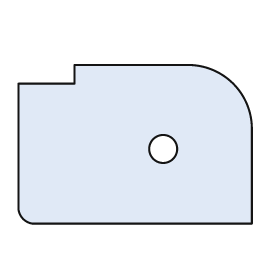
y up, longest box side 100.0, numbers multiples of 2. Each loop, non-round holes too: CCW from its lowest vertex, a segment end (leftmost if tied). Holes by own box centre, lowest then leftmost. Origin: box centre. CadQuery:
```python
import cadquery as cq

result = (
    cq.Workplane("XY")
    .moveTo(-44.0, -34.0)
    .lineTo(50.0, -34.0)
    .lineTo(50.0, 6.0)
    .threePointArc((42.0, 26.0), (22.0, 34.0))
    .lineTo(-26.0, 34.0)
    .lineTo(-26.0, 26.0)
    .lineTo(-50.0, 26.0)
    .lineTo(-50.0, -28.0)
    .threePointArc((-48.0, -32.0), (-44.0, -34.0))
    .close()
    .moveTo(12.0, -2.0)
    .circle(6.0)
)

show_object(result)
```